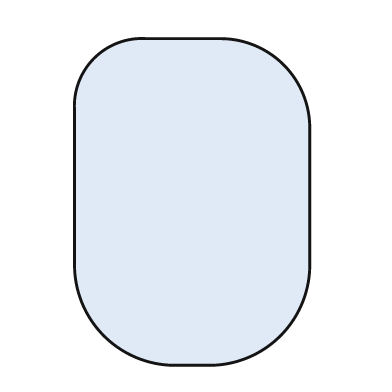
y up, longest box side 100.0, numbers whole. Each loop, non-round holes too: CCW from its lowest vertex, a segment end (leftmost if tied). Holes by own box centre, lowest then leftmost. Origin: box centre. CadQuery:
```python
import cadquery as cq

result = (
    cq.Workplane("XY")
    .moveTo(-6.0, -50.0)
    .lineTo(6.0, -50.0)
    .threePointArc((27.0, -41.0), (36.0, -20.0))
    .lineTo(36.0, 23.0)
    .threePointArc((28.0, 42.0), (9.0, 50.0))
    .lineTo(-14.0, 50.0)
    .threePointArc((-30.0, 44.0), (-36.0, 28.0))
    .lineTo(-36.0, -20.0)
    .threePointArc((-27.0, -41.0), (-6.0, -50.0))
    .close()
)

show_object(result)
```